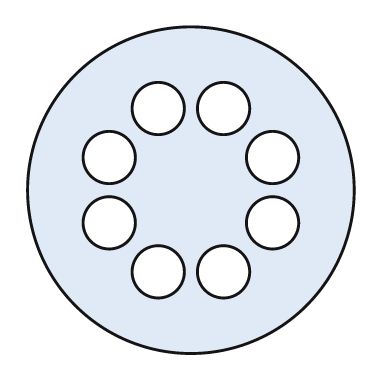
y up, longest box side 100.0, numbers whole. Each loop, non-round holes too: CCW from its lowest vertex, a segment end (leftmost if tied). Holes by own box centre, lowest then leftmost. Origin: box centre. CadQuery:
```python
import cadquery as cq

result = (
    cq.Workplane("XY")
    .moveTo(0.0, 0.0)
    .circle(50.0)
    .moveTo(-10.0, -25.0)
    .circle(8.0)
    .moveTo(10.0, -25.0)
    .circle(8.0)
    .moveTo(-25.0, -10.0)
    .circle(8.0)
    .moveTo(25.0, -10.0)
    .circle(8.0)
    .moveTo(-25.0, 10.0)
    .circle(8.0)
    .moveTo(25.0, 10.0)
    .circle(8.0)
    .moveTo(-10.0, 25.0)
    .circle(8.0)
    .moveTo(10.0, 25.0)
    .circle(8.0)
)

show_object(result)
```